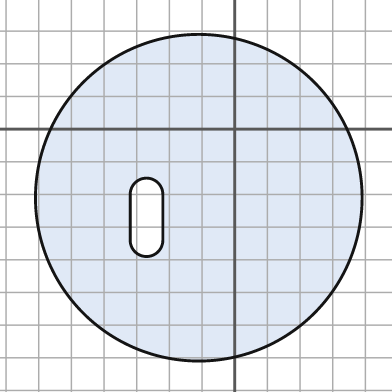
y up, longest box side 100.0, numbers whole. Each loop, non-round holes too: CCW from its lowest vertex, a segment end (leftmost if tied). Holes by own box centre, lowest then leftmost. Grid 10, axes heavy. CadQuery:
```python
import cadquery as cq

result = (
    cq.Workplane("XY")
    .moveTo(-11.0, -21.0)
    .circle(50.0)
    .moveTo(-32.0, -34.0)
    .threePointArc((-27.0, -39.0), (-22.0, -34.0))
    .lineTo(-22.0, -20.0)
    .threePointArc((-27.0, -15.0), (-32.0, -20.0))
    .close()
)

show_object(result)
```